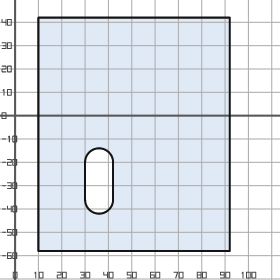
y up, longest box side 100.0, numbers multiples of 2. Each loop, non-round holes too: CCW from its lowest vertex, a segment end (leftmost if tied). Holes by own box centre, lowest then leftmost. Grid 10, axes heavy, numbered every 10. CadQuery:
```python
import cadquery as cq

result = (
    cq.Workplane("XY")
    .moveTo(10.0, -58.0)
    .lineTo(92.0, -58.0)
    .lineTo(92.0, 42.0)
    .lineTo(10.0, 42.0)
    .close()
    .moveTo(30.0, -36.0)
    .threePointArc((36.0, -42.0), (42.0, -36.0))
    .lineTo(42.0, -20.0)
    .threePointArc((36.0, -14.0), (30.0, -20.0))
    .close()
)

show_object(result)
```